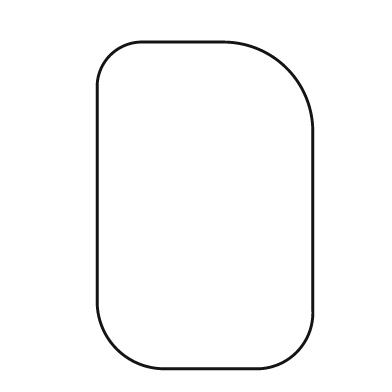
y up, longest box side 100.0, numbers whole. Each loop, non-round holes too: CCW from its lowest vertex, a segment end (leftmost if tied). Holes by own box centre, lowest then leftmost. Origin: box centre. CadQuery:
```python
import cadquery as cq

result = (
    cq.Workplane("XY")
    .moveTo(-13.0, -50.0)
    .lineTo(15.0, -50.0)
    .threePointArc((28.0, -45.0), (33.0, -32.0))
    .lineTo(33.0, 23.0)
    .threePointArc((25.0, 42.0), (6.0, 50.0))
    .lineTo(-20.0, 50.0)
    .threePointArc((-29.0, 46.0), (-33.0, 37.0))
    .lineTo(-33.0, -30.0)
    .threePointArc((-27.0, -44.0), (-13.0, -50.0))
    .close()
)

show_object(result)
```